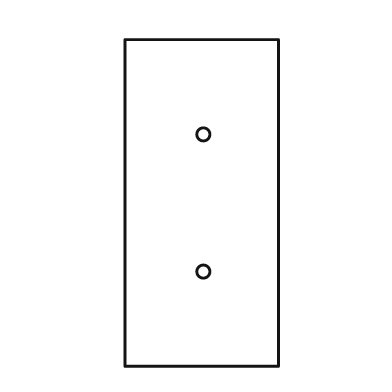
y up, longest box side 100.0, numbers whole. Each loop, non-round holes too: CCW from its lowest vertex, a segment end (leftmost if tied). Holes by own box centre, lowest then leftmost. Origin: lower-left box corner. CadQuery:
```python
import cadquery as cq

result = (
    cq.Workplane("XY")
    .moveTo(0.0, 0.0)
    .lineTo(47.0, 0.0)
    .lineTo(47.0, 100.0)
    .lineTo(0.0, 100.0)
    .close()
    .moveTo(24.0, 29.0)
    .circle(2.0)
    .moveTo(24.0, 71.0)
    .circle(2.0)
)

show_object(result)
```